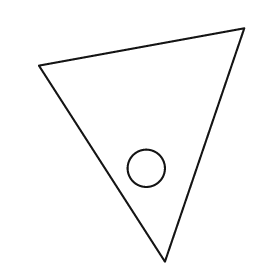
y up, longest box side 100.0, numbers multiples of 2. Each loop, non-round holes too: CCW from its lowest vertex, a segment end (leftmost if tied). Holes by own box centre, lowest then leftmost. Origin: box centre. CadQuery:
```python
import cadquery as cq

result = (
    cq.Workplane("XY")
    .moveTo(10.0, -50.0)
    .lineTo(44.0, 50.0)
    .lineTo(-44.0, 34.0)
    .close()
    .moveTo(2.0, -10.0)
    .circle(8.0)
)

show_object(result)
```